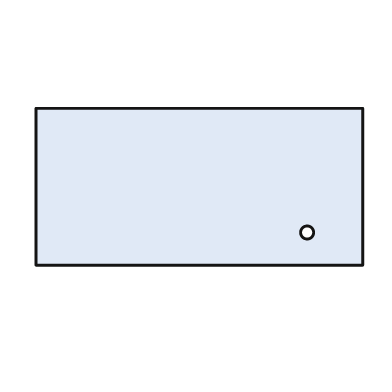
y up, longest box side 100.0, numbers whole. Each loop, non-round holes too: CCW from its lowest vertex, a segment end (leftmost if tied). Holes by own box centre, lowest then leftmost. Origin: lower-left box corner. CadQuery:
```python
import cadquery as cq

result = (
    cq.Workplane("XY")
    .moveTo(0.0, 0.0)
    .lineTo(100.0, 0.0)
    .lineTo(100.0, 48.0)
    .lineTo(0.0, 48.0)
    .close()
    .moveTo(83.0, 10.0)
    .circle(2.0)
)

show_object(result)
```